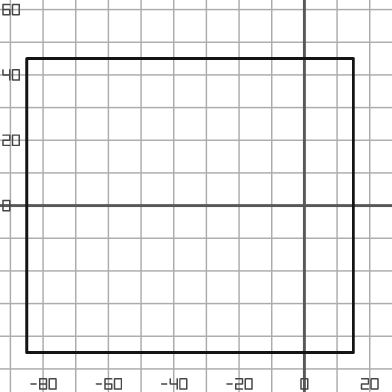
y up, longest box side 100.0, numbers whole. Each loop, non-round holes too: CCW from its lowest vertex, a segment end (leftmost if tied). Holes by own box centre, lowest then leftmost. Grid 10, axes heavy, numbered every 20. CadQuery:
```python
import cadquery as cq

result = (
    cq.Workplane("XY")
    .moveTo(-85.0, -45.0)
    .lineTo(15.0, -45.0)
    .lineTo(15.0, 45.0)
    .lineTo(-85.0, 45.0)
    .close()
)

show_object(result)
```